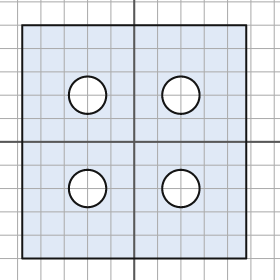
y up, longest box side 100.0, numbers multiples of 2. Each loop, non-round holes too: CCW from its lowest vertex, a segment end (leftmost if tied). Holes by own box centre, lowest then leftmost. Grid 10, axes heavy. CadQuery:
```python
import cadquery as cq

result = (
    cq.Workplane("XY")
    .moveTo(-48.0, -50.0)
    .lineTo(48.0, -50.0)
    .lineTo(48.0, 50.0)
    .lineTo(-48.0, 50.0)
    .close()
    .moveTo(-20.0, -20.0)
    .circle(8.0)
    .moveTo(20.0, -20.0)
    .circle(8.0)
    .moveTo(-20.0, 20.0)
    .circle(8.0)
    .moveTo(20.0, 20.0)
    .circle(8.0)
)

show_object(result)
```